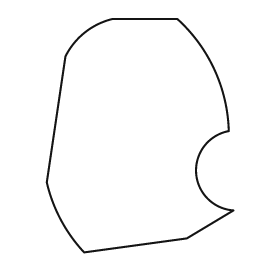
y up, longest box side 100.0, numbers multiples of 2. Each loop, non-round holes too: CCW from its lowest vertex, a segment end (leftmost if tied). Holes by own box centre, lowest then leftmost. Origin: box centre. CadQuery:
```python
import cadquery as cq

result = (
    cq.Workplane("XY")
    .moveTo(-24.0, -50.0)
    .lineTo(20.0, -44.0)
    .lineTo(40.0, -32.0)
    .threePointArc((24.0, -16.0), (38.0, 2.0))
    .threePointArc((32.0, 28.0), (16.0, 50.0))
    .lineTo(-12.0, 50.0)
    .threePointArc((-24.0, 44.0), (-32.0, 34.0))
    .lineTo(-40.0, -20.0)
    .threePointArc((-34.0, -36.0), (-24.0, -50.0))
    .close()
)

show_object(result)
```